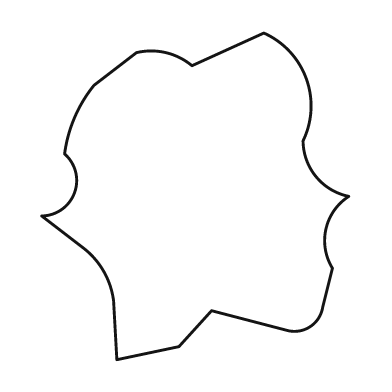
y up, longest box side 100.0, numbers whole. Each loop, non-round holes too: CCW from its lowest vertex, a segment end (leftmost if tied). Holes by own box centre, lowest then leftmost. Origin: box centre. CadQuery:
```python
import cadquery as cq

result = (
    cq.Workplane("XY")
    .moveTo(-24.0, -50.0)
    .lineTo(-5.0, -46.0)
    .lineTo(5.0, -35.0)
    .lineTo(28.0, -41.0)
    .threePointArc((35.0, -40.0), (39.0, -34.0))
    .lineTo(42.0, -22.0)
    .threePointArc((40.0, -10.0), (47.0, 0.0))
    .threePointArc((37.0, 6.0), (33.0, 17.0))
    .threePointArc((34.0, 36.0), (21.0, 50.0))
    .lineTo(-1.0, 40.0)
    .threePointArc((-9.0, 44.0), (-18.0, 44.0))
    .lineTo(-31.0, 34.0)
    .threePointArc((-37.0, 24.0), (-40.0, 13.0))
    .threePointArc((-37.0, 1.0), (-47.0, -6.0))
    .lineTo(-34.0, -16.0)
    .threePointArc((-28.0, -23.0), (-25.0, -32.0))
    .close()
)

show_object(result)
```